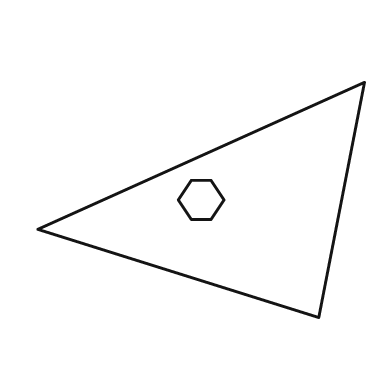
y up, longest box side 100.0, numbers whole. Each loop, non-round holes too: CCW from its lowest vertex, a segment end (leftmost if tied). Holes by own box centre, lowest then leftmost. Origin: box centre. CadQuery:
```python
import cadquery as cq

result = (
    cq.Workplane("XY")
    .moveTo(36.0, -36.0)
    .lineTo(50.0, 36.0)
    .lineTo(-50.0, -9.0)
    .close()
    .moveTo(-3.0, -6.0)
    .lineTo(3.0, -6.0)
    .lineTo(7.0, 0.0)
    .lineTo(3.0, 6.0)
    .lineTo(-3.0, 6.0)
    .lineTo(-7.0, 0.0)
    .close()
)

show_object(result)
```